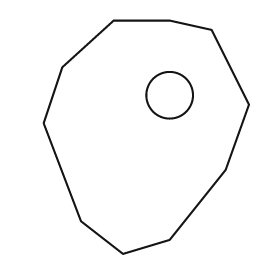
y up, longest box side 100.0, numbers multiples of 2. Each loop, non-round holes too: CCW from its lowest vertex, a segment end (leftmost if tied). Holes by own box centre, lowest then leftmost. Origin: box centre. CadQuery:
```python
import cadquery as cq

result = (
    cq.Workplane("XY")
    .moveTo(-10.0, -50.0)
    .lineTo(10.0, -44.0)
    .lineTo(34.0, -14.0)
    .lineTo(44.0, 14.0)
    .lineTo(28.0, 46.0)
    .lineTo(10.0, 50.0)
    .lineTo(-14.0, 50.0)
    .lineTo(-36.0, 30.0)
    .lineTo(-44.0, 6.0)
    .lineTo(-28.0, -36.0)
    .close()
    .moveTo(10.0, 18.0)
    .circle(10.0)
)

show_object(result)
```